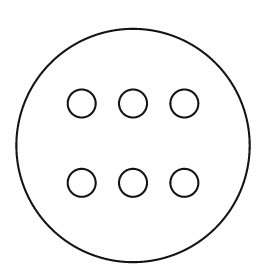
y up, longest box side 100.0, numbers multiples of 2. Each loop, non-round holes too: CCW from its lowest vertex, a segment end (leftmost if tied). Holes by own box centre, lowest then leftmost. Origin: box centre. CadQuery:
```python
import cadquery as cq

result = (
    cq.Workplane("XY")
    .moveTo(0.0, 0.0)
    .circle(50.0)
    .moveTo(-22.0, -16.0)
    .circle(6.0)
    .moveTo(0.0, -16.0)
    .circle(6.0)
    .moveTo(22.0, -16.0)
    .circle(6.0)
    .moveTo(-22.0, 18.0)
    .circle(6.0)
    .moveTo(0.0, 18.0)
    .circle(6.0)
    .moveTo(22.0, 18.0)
    .circle(6.0)
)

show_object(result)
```